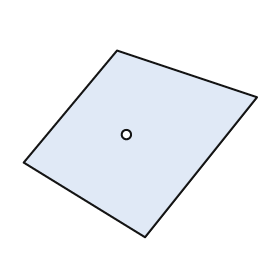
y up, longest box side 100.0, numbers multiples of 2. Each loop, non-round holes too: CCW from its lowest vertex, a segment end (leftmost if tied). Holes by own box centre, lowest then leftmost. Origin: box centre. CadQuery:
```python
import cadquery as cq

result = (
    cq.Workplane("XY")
    .moveTo(2.0, -40.0)
    .lineTo(50.0, 20.0)
    .lineTo(-10.0, 40.0)
    .lineTo(-50.0, -8.0)
    .close()
    .moveTo(-6.0, 4.0)
    .circle(2.0)
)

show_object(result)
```